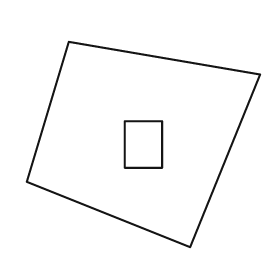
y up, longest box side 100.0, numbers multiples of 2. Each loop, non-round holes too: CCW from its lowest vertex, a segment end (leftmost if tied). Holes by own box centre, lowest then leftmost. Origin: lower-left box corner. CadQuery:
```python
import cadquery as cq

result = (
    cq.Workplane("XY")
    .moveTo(70.0, 0.0)
    .lineTo(100.0, 74.0)
    .lineTo(18.0, 88.0)
    .lineTo(0.0, 28.0)
    .close()
    .moveTo(42.0, 34.0)
    .lineTo(58.0, 34.0)
    .lineTo(58.0, 54.0)
    .lineTo(42.0, 54.0)
    .close()
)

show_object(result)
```